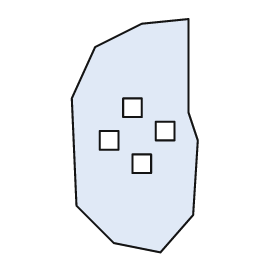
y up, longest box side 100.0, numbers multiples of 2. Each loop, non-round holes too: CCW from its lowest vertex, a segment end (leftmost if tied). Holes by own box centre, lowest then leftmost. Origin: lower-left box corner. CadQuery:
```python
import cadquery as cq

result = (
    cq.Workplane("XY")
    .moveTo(38.0, 0.0)
    .lineTo(52.0, 16.0)
    .lineTo(54.0, 48.0)
    .lineTo(50.0, 60.0)
    .lineTo(50.0, 100.0)
    .lineTo(30.0, 98.0)
    .lineTo(10.0, 88.0)
    .lineTo(0.0, 66.0)
    .lineTo(2.0, 20.0)
    .lineTo(18.0, 4.0)
    .close()
    .moveTo(26.0, 34.0)
    .lineTo(34.0, 34.0)
    .lineTo(34.0, 42.0)
    .lineTo(26.0, 42.0)
    .close()
    .moveTo(12.0, 44.0)
    .lineTo(20.0, 44.0)
    .lineTo(20.0, 52.0)
    .lineTo(12.0, 52.0)
    .close()
    .moveTo(36.0, 48.0)
    .lineTo(44.0, 48.0)
    .lineTo(44.0, 56.0)
    .lineTo(36.0, 56.0)
    .close()
    .moveTo(22.0, 58.0)
    .lineTo(30.0, 58.0)
    .lineTo(30.0, 66.0)
    .lineTo(22.0, 66.0)
    .close()
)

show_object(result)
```